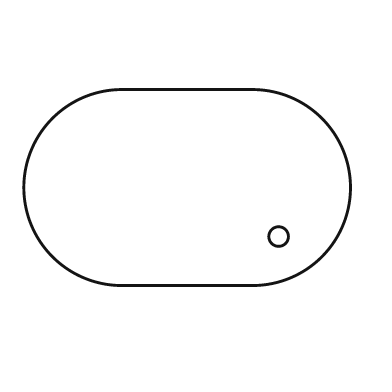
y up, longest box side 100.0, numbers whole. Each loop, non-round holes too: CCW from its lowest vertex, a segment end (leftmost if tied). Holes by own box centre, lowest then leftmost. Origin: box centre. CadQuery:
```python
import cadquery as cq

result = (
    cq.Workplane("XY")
    .moveTo(-20.0, -30.0)
    .lineTo(20.0, -30.0)
    .threePointArc((50.0, 0.0), (20.0, 30.0))
    .lineTo(-20.0, 30.0)
    .threePointArc((-50.0, 0.0), (-20.0, -30.0))
    .close()
    .moveTo(28.0, -15.0)
    .circle(3.0)
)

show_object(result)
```